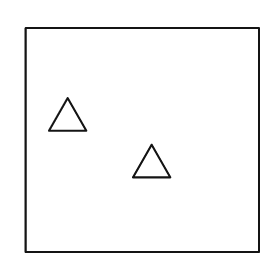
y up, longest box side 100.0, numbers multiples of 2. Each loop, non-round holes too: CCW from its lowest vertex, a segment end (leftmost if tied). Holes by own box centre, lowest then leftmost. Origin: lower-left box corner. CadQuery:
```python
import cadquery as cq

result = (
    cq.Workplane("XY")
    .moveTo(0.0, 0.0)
    .lineTo(100.0, 0.0)
    .lineTo(100.0, 96.0)
    .lineTo(0.0, 96.0)
    .close()
    .moveTo(46.0, 32.0)
    .lineTo(62.0, 32.0)
    .lineTo(54.0, 46.0)
    .close()
    .moveTo(10.0, 52.0)
    .lineTo(26.0, 52.0)
    .lineTo(18.0, 66.0)
    .close()
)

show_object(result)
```